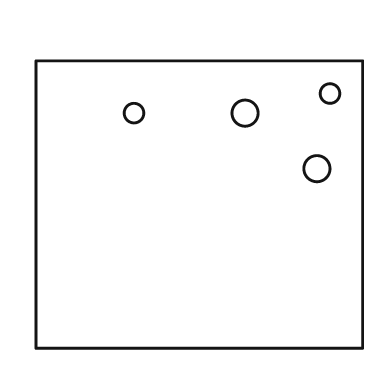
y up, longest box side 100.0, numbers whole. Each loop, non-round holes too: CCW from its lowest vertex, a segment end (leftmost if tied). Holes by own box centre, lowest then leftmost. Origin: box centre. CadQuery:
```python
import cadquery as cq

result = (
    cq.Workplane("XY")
    .moveTo(-50.0, -44.0)
    .lineTo(50.0, -44.0)
    .lineTo(50.0, 44.0)
    .lineTo(-50.0, 44.0)
    .close()
    .moveTo(36.0, 11.0)
    .circle(4.0)
    .moveTo(-20.0, 28.0)
    .circle(3.0)
    .moveTo(14.0, 28.0)
    .circle(4.0)
    .moveTo(40.0, 34.0)
    .circle(3.0)
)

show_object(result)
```